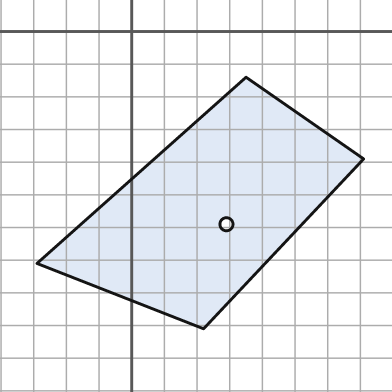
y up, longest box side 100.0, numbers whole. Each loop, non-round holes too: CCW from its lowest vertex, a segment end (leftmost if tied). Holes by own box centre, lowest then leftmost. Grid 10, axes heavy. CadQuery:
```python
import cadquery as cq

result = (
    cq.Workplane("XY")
    .moveTo(22.0, -91.0)
    .lineTo(71.0, -39.0)
    .lineTo(35.0, -14.0)
    .lineTo(-29.0, -71.0)
    .close()
    .moveTo(29.0, -59.0)
    .circle(2.0)
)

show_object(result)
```